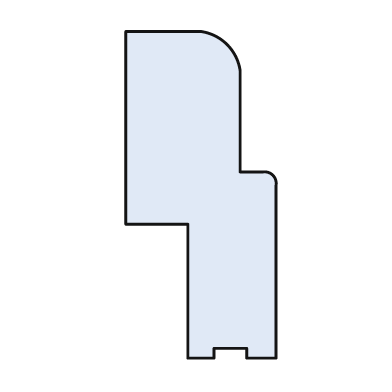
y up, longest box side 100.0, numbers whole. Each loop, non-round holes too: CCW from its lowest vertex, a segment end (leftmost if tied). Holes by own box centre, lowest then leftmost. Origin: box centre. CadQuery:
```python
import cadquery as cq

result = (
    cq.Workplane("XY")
    .moveTo(-4.0, -50.0)
    .lineTo(4.0, -50.0)
    .lineTo(4.0, -47.0)
    .lineTo(14.0, -47.0)
    .lineTo(14.0, -50.0)
    .lineTo(23.0, -50.0)
    .lineTo(23.0, 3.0)
    .threePointArc((22.0, 6.0), (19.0, 7.0))
    .lineTo(12.0, 7.0)
    .lineTo(12.0, 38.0)
    .threePointArc((8.0, 46.0), (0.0, 50.0))
    .lineTo(-23.0, 50.0)
    .lineTo(-23.0, -9.0)
    .lineTo(-4.0, -9.0)
    .close()
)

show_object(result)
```